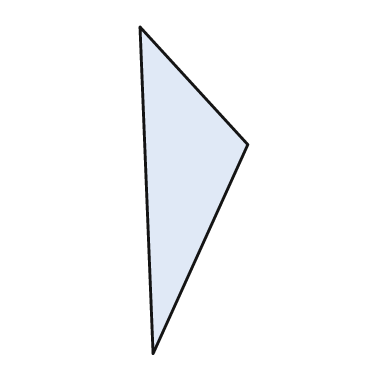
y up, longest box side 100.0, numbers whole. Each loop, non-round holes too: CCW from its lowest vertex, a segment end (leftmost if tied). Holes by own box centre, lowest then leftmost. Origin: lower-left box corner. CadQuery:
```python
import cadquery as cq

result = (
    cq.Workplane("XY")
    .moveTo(4.0, 0.0)
    .lineTo(33.0, 64.0)
    .lineTo(0.0, 100.0)
    .close()
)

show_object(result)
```